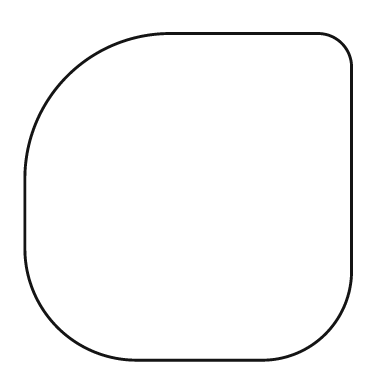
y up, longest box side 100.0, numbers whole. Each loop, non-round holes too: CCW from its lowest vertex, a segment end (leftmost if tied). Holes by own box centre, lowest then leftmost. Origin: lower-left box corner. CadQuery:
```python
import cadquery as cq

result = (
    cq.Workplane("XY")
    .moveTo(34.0, 0.0)
    .lineTo(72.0, 0.0)
    .threePointArc((92.0, 8.0), (100.0, 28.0))
    .lineTo(100.0, 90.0)
    .threePointArc((97.0, 97.0), (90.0, 100.0))
    .lineTo(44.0, 100.0)
    .threePointArc((13.0, 87.0), (0.0, 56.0))
    .lineTo(0.0, 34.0)
    .threePointArc((10.0, 10.0), (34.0, 0.0))
    .close()
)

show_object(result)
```